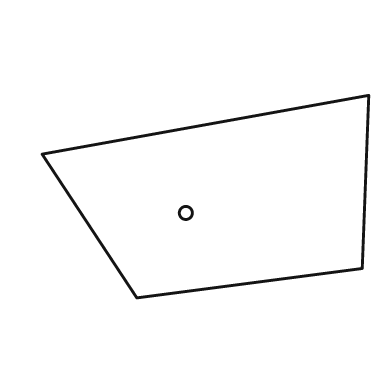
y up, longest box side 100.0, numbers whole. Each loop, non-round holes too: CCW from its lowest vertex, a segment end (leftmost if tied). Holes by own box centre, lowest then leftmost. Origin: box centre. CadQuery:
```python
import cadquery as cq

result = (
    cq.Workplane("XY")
    .moveTo(-21.0, -31.0)
    .lineTo(48.0, -22.0)
    .lineTo(50.0, 31.0)
    .lineTo(-50.0, 13.0)
    .close()
    .moveTo(-6.0, -5.0)
    .circle(2.0)
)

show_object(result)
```